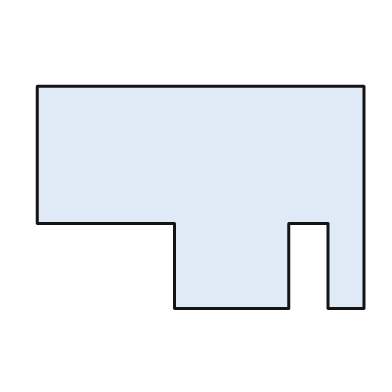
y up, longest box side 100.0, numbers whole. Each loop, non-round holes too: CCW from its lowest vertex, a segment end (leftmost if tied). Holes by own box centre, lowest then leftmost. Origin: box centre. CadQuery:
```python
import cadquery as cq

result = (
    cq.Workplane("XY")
    .moveTo(-8.0, -34.0)
    .lineTo(27.0, -34.0)
    .lineTo(27.0, -8.0)
    .lineTo(39.0, -8.0)
    .lineTo(39.0, -34.0)
    .lineTo(50.0, -34.0)
    .lineTo(50.0, 34.0)
    .lineTo(-50.0, 34.0)
    .lineTo(-50.0, -8.0)
    .lineTo(-8.0, -8.0)
    .close()
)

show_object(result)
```